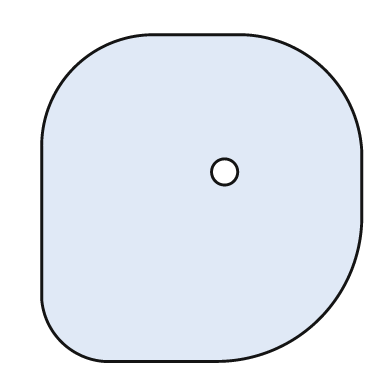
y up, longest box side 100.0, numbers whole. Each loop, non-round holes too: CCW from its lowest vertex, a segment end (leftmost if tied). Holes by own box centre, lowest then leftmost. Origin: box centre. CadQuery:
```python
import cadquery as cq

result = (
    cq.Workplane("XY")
    .moveTo(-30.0, -50.0)
    .lineTo(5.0, -50.0)
    .threePointArc((36.0, -37.0), (49.0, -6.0))
    .lineTo(49.0, 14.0)
    .threePointArc((38.0, 39.0), (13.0, 50.0))
    .lineTo(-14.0, 50.0)
    .threePointArc((-39.0, 40.0), (-49.0, 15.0))
    .lineTo(-49.0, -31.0)
    .threePointArc((-43.0, -44.0), (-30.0, -50.0))
    .close()
    .moveTo(7.0, 8.0)
    .circle(4.0)
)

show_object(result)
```